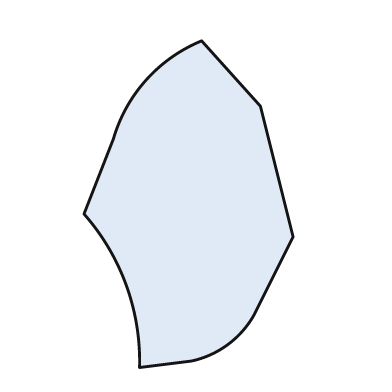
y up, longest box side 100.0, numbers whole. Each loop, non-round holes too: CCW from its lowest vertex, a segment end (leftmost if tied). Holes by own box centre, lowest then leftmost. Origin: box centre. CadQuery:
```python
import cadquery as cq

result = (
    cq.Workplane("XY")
    .moveTo(-15.0, -50.0)
    .lineTo(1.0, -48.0)
    .threePointArc((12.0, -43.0), (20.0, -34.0))
    .lineTo(32.0, -10.0)
    .lineTo(22.0, 30.0)
    .lineTo(4.0, 50.0)
    .threePointArc((-13.0, 38.0), (-23.0, 20.0))
    .lineTo(-32.0, -3.0)
    .threePointArc((-19.0, -25.0), (-15.0, -50.0))
    .close()
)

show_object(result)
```